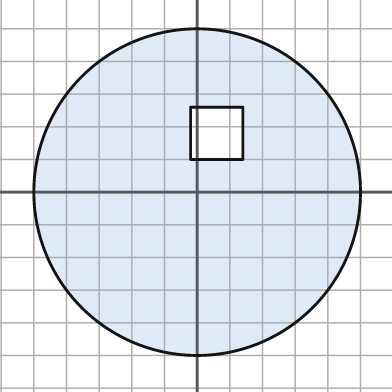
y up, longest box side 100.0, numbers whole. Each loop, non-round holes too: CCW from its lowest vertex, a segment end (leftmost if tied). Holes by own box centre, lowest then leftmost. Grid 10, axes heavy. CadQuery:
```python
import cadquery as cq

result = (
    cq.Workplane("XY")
    .moveTo(0.0, 0.0)
    .circle(50.0)
    .moveTo(-2.0, 10.0)
    .lineTo(14.0, 10.0)
    .lineTo(14.0, 26.0)
    .lineTo(-2.0, 26.0)
    .close()
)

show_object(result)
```